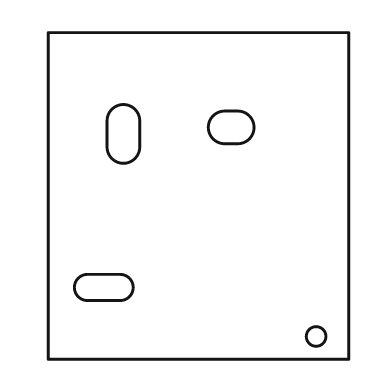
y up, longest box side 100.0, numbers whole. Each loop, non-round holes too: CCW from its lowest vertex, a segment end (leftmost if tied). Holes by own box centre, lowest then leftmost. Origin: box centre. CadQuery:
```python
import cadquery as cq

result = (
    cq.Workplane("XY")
    .moveTo(-46.0, -50.0)
    .lineTo(46.0, -50.0)
    .lineTo(46.0, 50.0)
    .lineTo(-46.0, 50.0)
    .close()
    .moveTo(36.0, -43.0)
    .circle(3.0)
    .moveTo(-34.0, -32.0)
    .lineTo(-24.0, -32.0)
    .threePointArc((-20.0, -28.0), (-24.0, -24.0))
    .lineTo(-34.0, -24.0)
    .threePointArc((-38.0, -28.0), (-34.0, -32.0))
    .close()
    .moveTo(-28.0, 15.0)
    .threePointArc((-23.0, 10.0), (-18.0, 15.0))
    .lineTo(-18.0, 23.0)
    .threePointArc((-23.0, 28.0), (-28.0, 23.0))
    .close()
    .moveTo(8.0, 16.0)
    .lineTo(12.0, 16.0)
    .threePointArc((17.0, 21.0), (12.0, 26.0))
    .lineTo(8.0, 26.0)
    .threePointArc((3.0, 21.0), (8.0, 16.0))
    .close()
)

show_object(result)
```